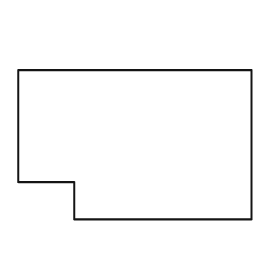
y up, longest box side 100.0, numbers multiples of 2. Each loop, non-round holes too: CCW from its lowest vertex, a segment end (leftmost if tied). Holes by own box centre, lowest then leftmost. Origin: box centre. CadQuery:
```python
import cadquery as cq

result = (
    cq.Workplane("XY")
    .moveTo(-26.0, -32.0)
    .lineTo(50.0, -32.0)
    .lineTo(50.0, 32.0)
    .lineTo(-50.0, 32.0)
    .lineTo(-50.0, -16.0)
    .lineTo(-26.0, -16.0)
    .close()
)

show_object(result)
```